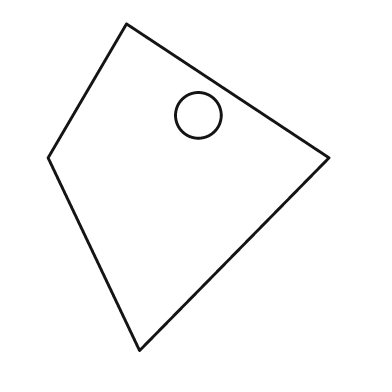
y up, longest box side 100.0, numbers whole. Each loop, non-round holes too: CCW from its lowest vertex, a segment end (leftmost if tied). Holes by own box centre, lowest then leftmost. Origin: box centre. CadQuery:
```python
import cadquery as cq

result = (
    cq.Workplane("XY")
    .moveTo(-15.0, -50.0)
    .lineTo(43.0, 9.0)
    .lineTo(-19.0, 50.0)
    .lineTo(-43.0, 9.0)
    .close()
    .moveTo(3.0, 22.0)
    .circle(7.0)
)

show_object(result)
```